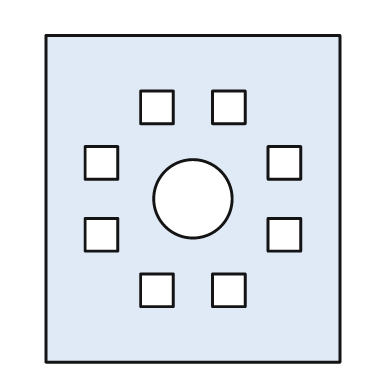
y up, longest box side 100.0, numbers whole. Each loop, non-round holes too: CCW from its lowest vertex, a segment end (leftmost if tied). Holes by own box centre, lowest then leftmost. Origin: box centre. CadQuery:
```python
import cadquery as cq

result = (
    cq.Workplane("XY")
    .moveTo(-45.0, -50.0)
    .lineTo(45.0, -50.0)
    .lineTo(45.0, 50.0)
    .lineTo(-45.0, 50.0)
    .close()
    .moveTo(-16.0, -33.0)
    .lineTo(-6.0, -33.0)
    .lineTo(-6.0, -23.0)
    .lineTo(-16.0, -23.0)
    .close()
    .moveTo(6.0, -33.0)
    .lineTo(16.0, -33.0)
    .lineTo(16.0, -23.0)
    .lineTo(6.0, -23.0)
    .close()
    .moveTo(-33.0, -16.0)
    .lineTo(-23.0, -16.0)
    .lineTo(-23.0, -6.0)
    .lineTo(-33.0, -6.0)
    .close()
    .moveTo(23.0, -16.0)
    .lineTo(33.0, -16.0)
    .lineTo(33.0, -6.0)
    .lineTo(23.0, -6.0)
    .close()
    .moveTo(0.0, 0.0)
    .circle(12.0)
    .moveTo(-33.0, 6.0)
    .lineTo(-23.0, 6.0)
    .lineTo(-23.0, 16.0)
    .lineTo(-33.0, 16.0)
    .close()
    .moveTo(23.0, 6.0)
    .lineTo(33.0, 6.0)
    .lineTo(33.0, 16.0)
    .lineTo(23.0, 16.0)
    .close()
    .moveTo(-16.0, 23.0)
    .lineTo(-6.0, 23.0)
    .lineTo(-6.0, 33.0)
    .lineTo(-16.0, 33.0)
    .close()
    .moveTo(6.0, 23.0)
    .lineTo(16.0, 23.0)
    .lineTo(16.0, 33.0)
    .lineTo(6.0, 33.0)
    .close()
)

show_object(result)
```